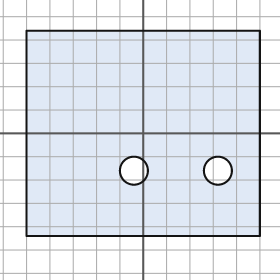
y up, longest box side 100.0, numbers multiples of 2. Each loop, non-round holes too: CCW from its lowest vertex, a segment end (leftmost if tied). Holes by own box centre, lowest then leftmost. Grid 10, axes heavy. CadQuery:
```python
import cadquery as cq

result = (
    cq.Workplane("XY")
    .moveTo(-50.0, -44.0)
    .lineTo(50.0, -44.0)
    .lineTo(50.0, 44.0)
    .lineTo(-50.0, 44.0)
    .close()
    .moveTo(-4.0, -16.0)
    .circle(6.0)
    .moveTo(32.0, -16.0)
    .circle(6.0)
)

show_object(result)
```